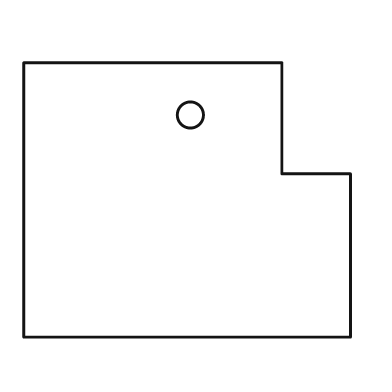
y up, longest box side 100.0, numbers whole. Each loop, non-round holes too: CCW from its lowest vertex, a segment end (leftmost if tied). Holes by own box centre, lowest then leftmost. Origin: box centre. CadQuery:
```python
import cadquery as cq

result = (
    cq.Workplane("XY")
    .moveTo(-50.0, -42.0)
    .lineTo(50.0, -42.0)
    .lineTo(50.0, 8.0)
    .lineTo(29.0, 8.0)
    .lineTo(29.0, 42.0)
    .lineTo(-50.0, 42.0)
    .close()
    .moveTo(1.0, 26.0)
    .circle(4.0)
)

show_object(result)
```